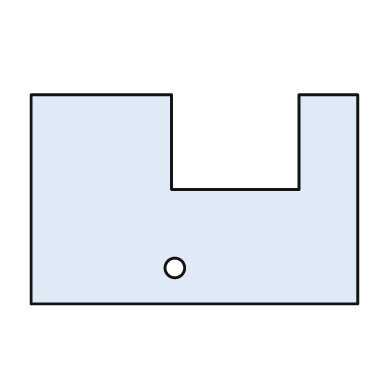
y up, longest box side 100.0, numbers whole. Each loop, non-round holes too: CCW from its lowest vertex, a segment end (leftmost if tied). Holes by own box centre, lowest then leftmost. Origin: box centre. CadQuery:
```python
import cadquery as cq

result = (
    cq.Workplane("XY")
    .moveTo(-50.0, -32.0)
    .lineTo(50.0, -32.0)
    .lineTo(50.0, 32.0)
    .lineTo(32.0, 32.0)
    .lineTo(32.0, 3.0)
    .lineTo(-7.0, 3.0)
    .lineTo(-7.0, 32.0)
    .lineTo(-50.0, 32.0)
    .close()
    .moveTo(-6.0, -21.0)
    .circle(3.0)
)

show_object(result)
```